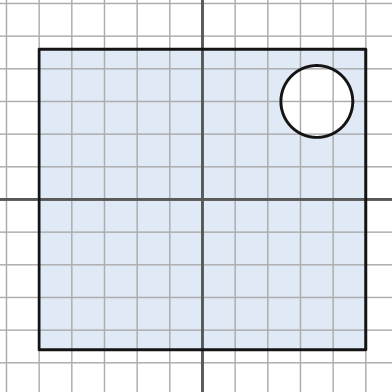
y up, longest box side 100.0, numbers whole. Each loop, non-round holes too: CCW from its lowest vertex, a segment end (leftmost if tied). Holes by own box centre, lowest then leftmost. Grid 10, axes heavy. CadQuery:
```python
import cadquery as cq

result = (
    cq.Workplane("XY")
    .moveTo(-50.0, -46.0)
    .lineTo(50.0, -46.0)
    .lineTo(50.0, 46.0)
    .lineTo(-50.0, 46.0)
    .close()
    .moveTo(35.0, 30.0)
    .circle(11.0)
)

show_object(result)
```